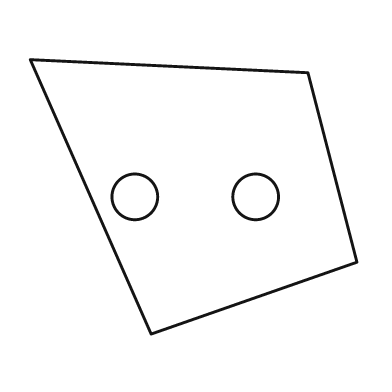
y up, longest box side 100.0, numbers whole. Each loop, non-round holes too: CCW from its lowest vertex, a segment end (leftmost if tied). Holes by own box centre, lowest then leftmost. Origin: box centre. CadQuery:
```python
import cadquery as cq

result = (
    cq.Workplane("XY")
    .moveTo(-13.0, -42.0)
    .lineTo(50.0, -20.0)
    .lineTo(35.0, 38.0)
    .lineTo(-50.0, 42.0)
    .close()
    .moveTo(-18.0, 0.0)
    .circle(7.0)
    .moveTo(19.0, 0.0)
    .circle(7.0)
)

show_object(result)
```